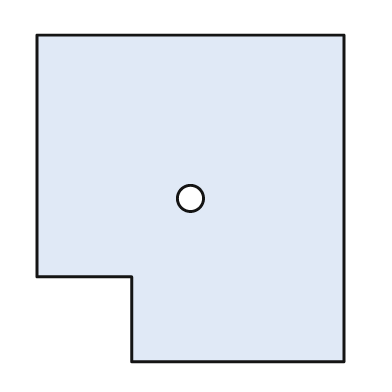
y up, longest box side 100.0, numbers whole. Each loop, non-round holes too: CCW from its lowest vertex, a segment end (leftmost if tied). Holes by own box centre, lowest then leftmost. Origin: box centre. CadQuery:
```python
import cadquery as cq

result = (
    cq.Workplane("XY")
    .moveTo(-18.0, -50.0)
    .lineTo(47.0, -50.0)
    .lineTo(47.0, 50.0)
    .lineTo(-47.0, 50.0)
    .lineTo(-47.0, -24.0)
    .lineTo(-18.0, -24.0)
    .close()
    .moveTo(0.0, 0.0)
    .circle(4.0)
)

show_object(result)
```